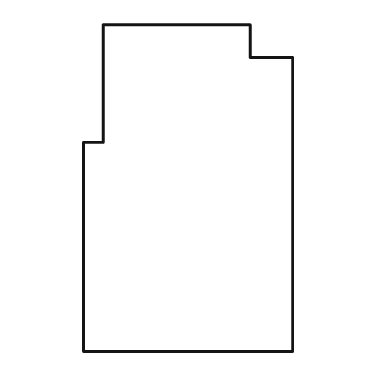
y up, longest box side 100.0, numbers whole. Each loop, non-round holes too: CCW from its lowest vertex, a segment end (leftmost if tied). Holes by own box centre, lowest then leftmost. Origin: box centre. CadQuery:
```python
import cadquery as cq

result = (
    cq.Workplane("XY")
    .moveTo(-32.0, -50.0)
    .lineTo(32.0, -50.0)
    .lineTo(32.0, 40.0)
    .lineTo(19.0, 40.0)
    .lineTo(19.0, 50.0)
    .lineTo(-26.0, 50.0)
    .lineTo(-26.0, 14.0)
    .lineTo(-32.0, 14.0)
    .close()
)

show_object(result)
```